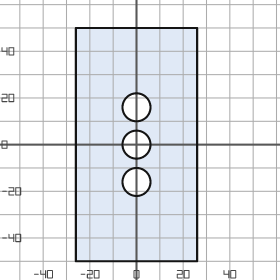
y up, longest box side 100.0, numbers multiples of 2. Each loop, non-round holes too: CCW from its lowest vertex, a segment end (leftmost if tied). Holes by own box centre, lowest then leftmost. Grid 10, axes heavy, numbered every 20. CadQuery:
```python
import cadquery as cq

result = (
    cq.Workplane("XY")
    .moveTo(-26.0, -50.0)
    .lineTo(26.0, -50.0)
    .lineTo(26.0, 50.0)
    .lineTo(-26.0, 50.0)
    .close()
    .moveTo(0.0, -16.0)
    .circle(6.0)
    .moveTo(0.0, 0.0)
    .circle(6.0)
    .moveTo(0.0, 16.0)
    .circle(6.0)
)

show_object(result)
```